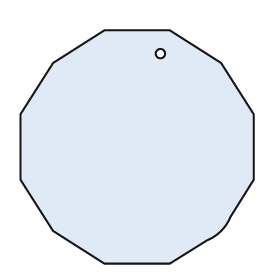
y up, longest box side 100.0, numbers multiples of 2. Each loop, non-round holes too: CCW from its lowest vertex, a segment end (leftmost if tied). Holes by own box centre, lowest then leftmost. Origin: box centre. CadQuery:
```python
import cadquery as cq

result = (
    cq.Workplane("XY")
    .moveTo(-14.0, -50.0)
    .lineTo(14.0, -50.0)
    .lineTo(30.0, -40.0)
    .threePointArc((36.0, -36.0), (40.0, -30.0))
    .lineTo(50.0, -14.0)
    .lineTo(50.0, 14.0)
    .lineTo(36.0, 36.0)
    .lineTo(14.0, 50.0)
    .lineTo(-14.0, 50.0)
    .lineTo(-36.0, 36.0)
    .lineTo(-50.0, 14.0)
    .lineTo(-50.0, -14.0)
    .lineTo(-36.0, -36.0)
    .close()
    .moveTo(10.0, 40.0)
    .circle(2.0)
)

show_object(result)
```